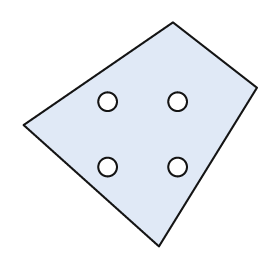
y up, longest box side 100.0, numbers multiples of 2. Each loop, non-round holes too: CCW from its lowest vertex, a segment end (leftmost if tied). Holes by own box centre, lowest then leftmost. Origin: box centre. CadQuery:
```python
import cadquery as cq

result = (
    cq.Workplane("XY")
    .moveTo(8.0, -48.0)
    .lineTo(50.0, 20.0)
    .lineTo(14.0, 48.0)
    .lineTo(-50.0, 4.0)
    .close()
    .moveTo(-14.0, -14.0)
    .circle(4.0)
    .moveTo(16.0, -14.0)
    .circle(4.0)
    .moveTo(-14.0, 14.0)
    .circle(4.0)
    .moveTo(16.0, 14.0)
    .circle(4.0)
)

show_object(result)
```